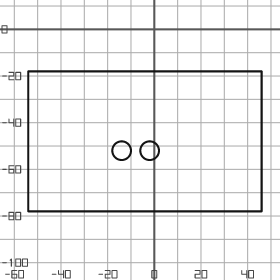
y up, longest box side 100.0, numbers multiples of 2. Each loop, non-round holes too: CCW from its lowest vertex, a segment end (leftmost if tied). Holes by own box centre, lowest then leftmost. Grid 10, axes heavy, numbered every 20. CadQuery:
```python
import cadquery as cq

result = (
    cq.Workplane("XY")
    .moveTo(-54.0, -78.0)
    .lineTo(46.0, -78.0)
    .lineTo(46.0, -18.0)
    .lineTo(-54.0, -18.0)
    .close()
    .moveTo(-14.0, -52.0)
    .circle(4.0)
    .moveTo(-2.0, -52.0)
    .circle(4.0)
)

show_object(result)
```